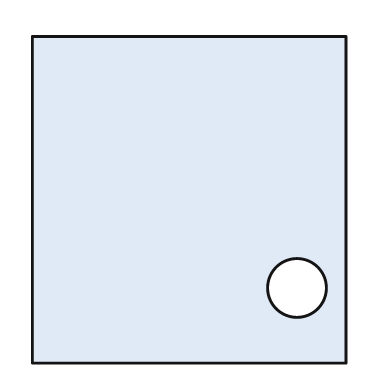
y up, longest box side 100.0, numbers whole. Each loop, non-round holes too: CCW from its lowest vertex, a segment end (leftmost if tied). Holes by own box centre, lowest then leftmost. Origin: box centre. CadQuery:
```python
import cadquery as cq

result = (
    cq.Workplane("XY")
    .moveTo(-48.0, -50.0)
    .lineTo(48.0, -50.0)
    .lineTo(48.0, 50.0)
    .lineTo(-48.0, 50.0)
    .close()
    .moveTo(33.0, -27.0)
    .circle(9.0)
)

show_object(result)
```